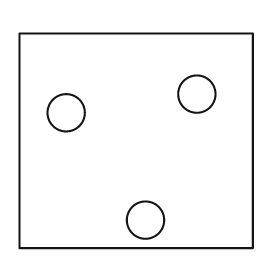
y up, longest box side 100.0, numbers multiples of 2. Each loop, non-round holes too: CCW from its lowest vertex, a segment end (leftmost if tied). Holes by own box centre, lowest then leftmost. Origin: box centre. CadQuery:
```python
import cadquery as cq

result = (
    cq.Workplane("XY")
    .moveTo(-50.0, -46.0)
    .lineTo(50.0, -46.0)
    .lineTo(50.0, 46.0)
    .lineTo(-50.0, 46.0)
    .close()
    .moveTo(4.0, -34.0)
    .circle(8.0)
    .moveTo(-30.0, 12.0)
    .circle(8.0)
    .moveTo(26.0, 20.0)
    .circle(8.0)
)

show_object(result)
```